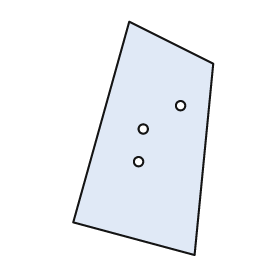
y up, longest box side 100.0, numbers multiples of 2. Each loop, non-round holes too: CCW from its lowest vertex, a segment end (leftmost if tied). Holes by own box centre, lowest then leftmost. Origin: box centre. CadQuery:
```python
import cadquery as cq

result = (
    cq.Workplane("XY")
    .moveTo(22.0, -50.0)
    .lineTo(30.0, 32.0)
    .lineTo(-6.0, 50.0)
    .lineTo(-30.0, -36.0)
    .close()
    .moveTo(-2.0, -10.0)
    .circle(2.0)
    .moveTo(0.0, 4.0)
    .circle(2.0)
    .moveTo(16.0, 14.0)
    .circle(2.0)
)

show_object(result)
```